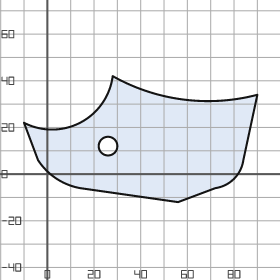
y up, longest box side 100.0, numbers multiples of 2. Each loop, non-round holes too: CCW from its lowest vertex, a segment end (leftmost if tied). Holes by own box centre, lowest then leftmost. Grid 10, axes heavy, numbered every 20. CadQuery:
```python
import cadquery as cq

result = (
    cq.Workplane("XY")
    .moveTo(56.0, -12.0)
    .lineTo(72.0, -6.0)
    .threePointArc((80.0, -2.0), (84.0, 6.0))
    .lineTo(90.0, 34.0)
    .threePointArc((58.0, 32.0), (28.0, 42.0))
    .threePointArc((14.0, 22.0), (-10.0, 22.0))
    .lineTo(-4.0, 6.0)
    .threePointArc((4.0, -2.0), (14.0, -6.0))
    .close()
    .moveTo(26.0, 12.0)
    .circle(4.0)
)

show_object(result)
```